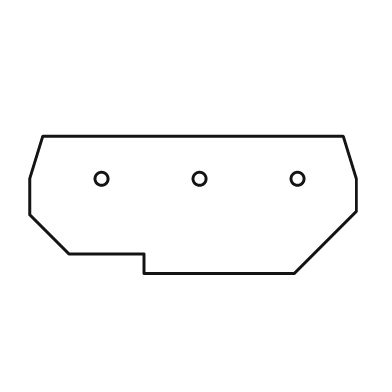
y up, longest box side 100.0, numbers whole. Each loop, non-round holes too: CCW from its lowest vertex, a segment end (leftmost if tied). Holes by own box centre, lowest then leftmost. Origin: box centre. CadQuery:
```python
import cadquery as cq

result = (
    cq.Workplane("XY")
    .moveTo(-15.0, -21.0)
    .lineTo(31.0, -21.0)
    .lineTo(50.0, -2.0)
    .lineTo(50.0, 8.0)
    .lineTo(46.0, 21.0)
    .lineTo(-46.0, 21.0)
    .lineTo(-50.0, 8.0)
    .lineTo(-50.0, -3.0)
    .lineTo(-38.0, -15.0)
    .lineTo(-15.0, -15.0)
    .close()
    .moveTo(-28.0, 8.0)
    .circle(2.0)
    .moveTo(2.0, 8.0)
    .circle(2.0)
    .moveTo(32.0, 8.0)
    .circle(2.0)
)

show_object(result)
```